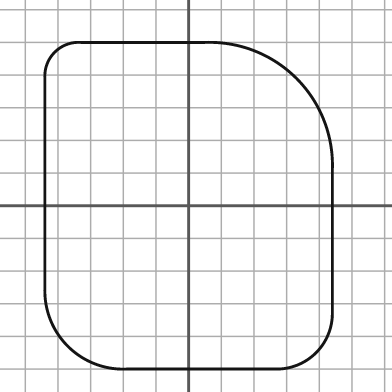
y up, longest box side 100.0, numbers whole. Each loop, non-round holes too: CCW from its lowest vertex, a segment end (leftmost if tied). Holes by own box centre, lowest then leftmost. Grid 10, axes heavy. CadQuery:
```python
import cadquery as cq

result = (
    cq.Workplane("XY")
    .moveTo(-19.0, -50.0)
    .lineTo(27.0, -50.0)
    .threePointArc((39.0, -45.0), (44.0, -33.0))
    .lineTo(44.0, 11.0)
    .threePointArc((33.0, 39.0), (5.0, 50.0))
    .lineTo(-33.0, 50.0)
    .threePointArc((-41.0, 47.0), (-44.0, 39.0))
    .lineTo(-44.0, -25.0)
    .threePointArc((-37.0, -43.0), (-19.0, -50.0))
    .close()
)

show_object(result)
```